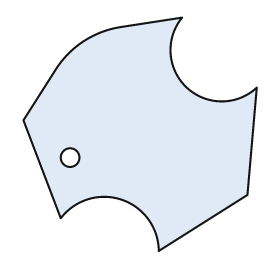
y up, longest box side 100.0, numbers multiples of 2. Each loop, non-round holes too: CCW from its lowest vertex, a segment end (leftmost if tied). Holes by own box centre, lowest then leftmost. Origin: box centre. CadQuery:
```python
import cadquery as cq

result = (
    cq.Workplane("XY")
    .moveTo(8.0, -50.0)
    .lineTo(46.0, -26.0)
    .lineTo(50.0, 20.0)
    .threePointArc((20.0, 20.0), (18.0, 50.0))
    .lineTo(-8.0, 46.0)
    .threePointArc((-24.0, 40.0), (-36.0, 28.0))
    .lineTo(-50.0, 6.0)
    .lineTo(-34.0, -36.0)
    .threePointArc((-8.0, -28.0), (8.0, -50.0))
    .close()
    .moveTo(-30.0, -10.0)
    .circle(4.0)
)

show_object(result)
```